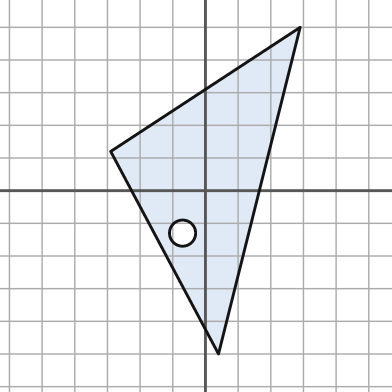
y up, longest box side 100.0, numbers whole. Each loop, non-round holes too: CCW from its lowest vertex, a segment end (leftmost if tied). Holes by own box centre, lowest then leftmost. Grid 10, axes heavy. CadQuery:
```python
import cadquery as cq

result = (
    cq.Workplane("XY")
    .moveTo(4.0, -50.0)
    .lineTo(29.0, 50.0)
    .lineTo(-29.0, 12.0)
    .close()
    .moveTo(-7.0, -13.0)
    .circle(4.0)
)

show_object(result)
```